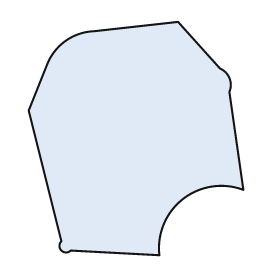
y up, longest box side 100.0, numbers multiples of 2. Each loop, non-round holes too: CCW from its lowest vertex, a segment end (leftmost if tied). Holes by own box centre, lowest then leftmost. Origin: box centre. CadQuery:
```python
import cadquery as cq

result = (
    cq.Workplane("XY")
    .moveTo(10.0, -50.0)
    .threePointArc((20.0, -26.0), (46.0, -22.0))
    .lineTo(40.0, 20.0)
    .threePointArc((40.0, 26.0), (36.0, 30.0))
    .lineTo(18.0, 50.0)
    .lineTo(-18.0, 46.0)
    .threePointArc((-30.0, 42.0), (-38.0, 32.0))
    .lineTo(-46.0, 12.0)
    .lineTo(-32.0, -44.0)
    .threePointArc((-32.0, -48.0), (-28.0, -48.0))
    .close()
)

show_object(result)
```